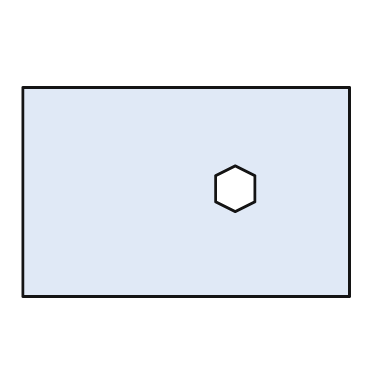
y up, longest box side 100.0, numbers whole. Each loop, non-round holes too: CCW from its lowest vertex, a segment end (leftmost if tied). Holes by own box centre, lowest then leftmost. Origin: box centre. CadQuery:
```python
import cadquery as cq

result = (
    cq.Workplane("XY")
    .moveTo(-50.0, -32.0)
    .lineTo(50.0, -32.0)
    .lineTo(50.0, 32.0)
    .lineTo(-50.0, 32.0)
    .close()
    .moveTo(15.0, -6.0)
    .lineTo(21.0, -3.0)
    .lineTo(21.0, 5.0)
    .lineTo(15.0, 8.0)
    .lineTo(9.0, 5.0)
    .lineTo(9.0, -3.0)
    .close()
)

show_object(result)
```